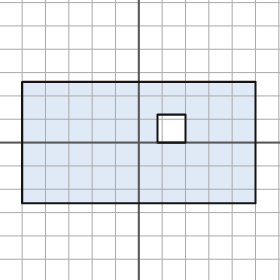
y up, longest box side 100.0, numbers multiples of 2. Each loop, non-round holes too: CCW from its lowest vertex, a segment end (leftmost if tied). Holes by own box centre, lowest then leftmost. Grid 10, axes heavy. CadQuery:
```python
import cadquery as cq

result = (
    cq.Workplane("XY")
    .moveTo(-50.0, -26.0)
    .lineTo(50.0, -26.0)
    .lineTo(50.0, 26.0)
    .lineTo(-50.0, 26.0)
    .close()
    .moveTo(8.0, 0.0)
    .lineTo(20.0, 0.0)
    .lineTo(20.0, 12.0)
    .lineTo(8.0, 12.0)
    .close()
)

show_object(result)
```